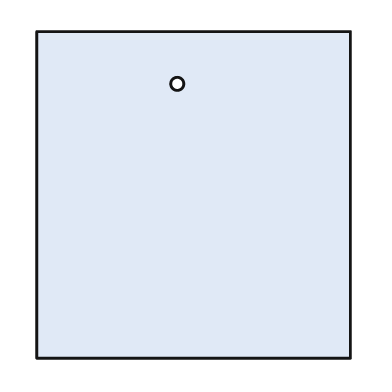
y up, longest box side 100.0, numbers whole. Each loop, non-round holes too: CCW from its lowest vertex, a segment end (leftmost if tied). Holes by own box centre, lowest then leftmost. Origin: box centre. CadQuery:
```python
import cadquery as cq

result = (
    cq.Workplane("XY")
    .moveTo(-48.0, -50.0)
    .lineTo(48.0, -50.0)
    .lineTo(48.0, 50.0)
    .lineTo(-48.0, 50.0)
    .close()
    .moveTo(-5.0, 34.0)
    .circle(2.0)
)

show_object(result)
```